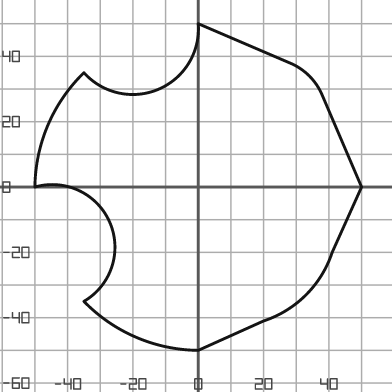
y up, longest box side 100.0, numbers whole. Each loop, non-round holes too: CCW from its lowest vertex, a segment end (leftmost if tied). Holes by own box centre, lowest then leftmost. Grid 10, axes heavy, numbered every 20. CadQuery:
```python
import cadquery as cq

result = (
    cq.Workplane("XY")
    .moveTo(0.0, -50.0)
    .lineTo(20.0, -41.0)
    .threePointArc((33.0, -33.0), (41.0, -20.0))
    .lineTo(50.0, 0.0)
    .lineTo(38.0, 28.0)
    .threePointArc((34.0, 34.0), (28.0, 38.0))
    .lineTo(0.0, 50.0)
    .threePointArc((-12.0, 30.0), (-35.0, 35.0))
    .threePointArc((-46.0, 19.0), (-50.0, 0.0))
    .threePointArc((-27.0, -11.0), (-35.0, -35.0))
    .threePointArc((-19.0, -46.0), (0.0, -50.0))
    .close()
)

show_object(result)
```